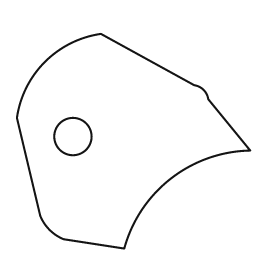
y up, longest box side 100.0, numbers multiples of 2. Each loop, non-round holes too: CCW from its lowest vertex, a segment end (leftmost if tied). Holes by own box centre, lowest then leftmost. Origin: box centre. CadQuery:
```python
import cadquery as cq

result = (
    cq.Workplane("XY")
    .moveTo(-4.0, -46.0)
    .threePointArc((16.0, -16.0), (50.0, -4.0))
    .lineTo(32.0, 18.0)
    .threePointArc((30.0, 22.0), (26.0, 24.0))
    .lineTo(-14.0, 46.0)
    .threePointArc((-38.0, 34.0), (-50.0, 10.0))
    .lineTo(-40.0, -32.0)
    .threePointArc((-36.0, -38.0), (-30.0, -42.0))
    .close()
    .moveTo(-26.0, 2.0)
    .circle(8.0)
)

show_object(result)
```